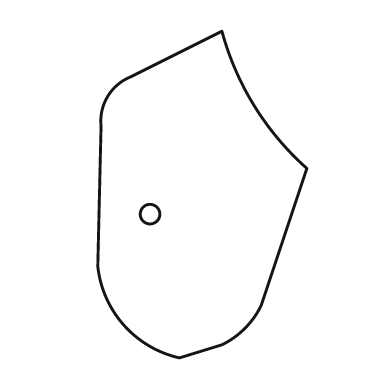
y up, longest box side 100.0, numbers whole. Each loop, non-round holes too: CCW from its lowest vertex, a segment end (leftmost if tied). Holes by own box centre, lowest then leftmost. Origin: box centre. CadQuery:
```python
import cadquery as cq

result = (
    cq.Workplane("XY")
    .moveTo(-7.0, -50.0)
    .lineTo(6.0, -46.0)
    .threePointArc((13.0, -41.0), (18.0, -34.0))
    .lineTo(32.0, 8.0)
    .threePointArc((16.0, 27.0), (6.0, 50.0))
    .lineTo(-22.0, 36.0)
    .threePointArc((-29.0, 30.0), (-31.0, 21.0))
    .lineTo(-32.0, -22.0)
    .threePointArc((-24.0, -40.0), (-7.0, -50.0))
    .close()
    .moveTo(-16.0, -6.0)
    .circle(3.0)
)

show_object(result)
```